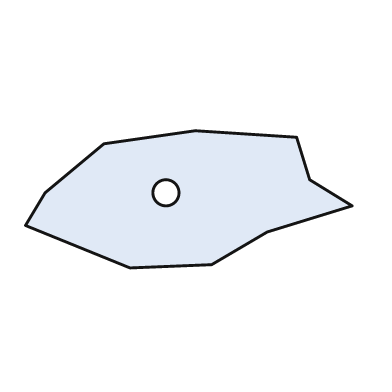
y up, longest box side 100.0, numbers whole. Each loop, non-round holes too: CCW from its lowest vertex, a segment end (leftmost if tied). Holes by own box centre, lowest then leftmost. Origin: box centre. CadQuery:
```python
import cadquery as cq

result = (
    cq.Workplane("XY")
    .moveTo(-18.0, -21.0)
    .lineTo(7.0, -20.0)
    .lineTo(24.0, -10.0)
    .lineTo(50.0, -2.0)
    .lineTo(37.0, 6.0)
    .lineTo(33.0, 19.0)
    .lineTo(2.0, 21.0)
    .lineTo(-26.0, 17.0)
    .lineTo(-44.0, 2.0)
    .lineTo(-50.0, -8.0)
    .close()
    .moveTo(-7.0, 2.0)
    .circle(4.0)
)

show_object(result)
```